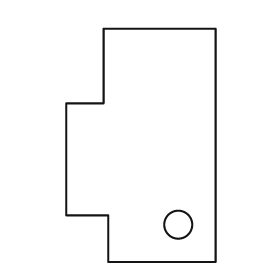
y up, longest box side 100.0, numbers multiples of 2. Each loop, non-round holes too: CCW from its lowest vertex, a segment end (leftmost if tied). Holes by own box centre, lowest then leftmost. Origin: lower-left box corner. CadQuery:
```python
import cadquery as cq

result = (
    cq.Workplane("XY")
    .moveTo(18.0, 0.0)
    .lineTo(64.0, 0.0)
    .lineTo(64.0, 100.0)
    .lineTo(16.0, 100.0)
    .lineTo(16.0, 68.0)
    .lineTo(0.0, 68.0)
    .lineTo(0.0, 20.0)
    .lineTo(18.0, 20.0)
    .close()
    .moveTo(48.0, 16.0)
    .circle(6.0)
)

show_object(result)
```